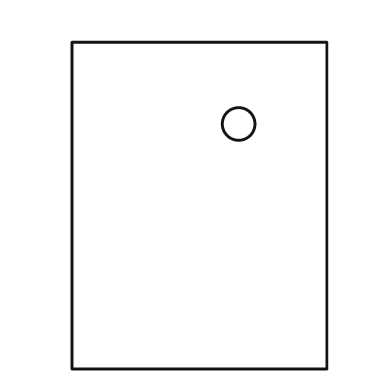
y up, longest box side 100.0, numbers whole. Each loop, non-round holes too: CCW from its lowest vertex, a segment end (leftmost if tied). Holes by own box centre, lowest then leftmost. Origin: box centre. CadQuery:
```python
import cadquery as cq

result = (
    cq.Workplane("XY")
    .moveTo(-39.0, -50.0)
    .lineTo(39.0, -50.0)
    .lineTo(39.0, 50.0)
    .lineTo(-39.0, 50.0)
    .close()
    .moveTo(12.0, 25.0)
    .circle(5.0)
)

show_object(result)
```